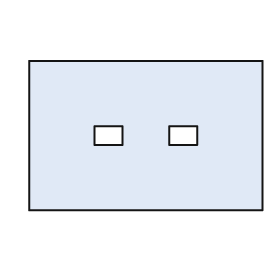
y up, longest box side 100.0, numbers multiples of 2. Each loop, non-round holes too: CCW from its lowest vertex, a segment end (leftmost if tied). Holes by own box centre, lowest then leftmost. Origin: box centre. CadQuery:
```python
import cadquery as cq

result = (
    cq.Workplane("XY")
    .moveTo(-50.0, -32.0)
    .lineTo(50.0, -32.0)
    .lineTo(50.0, 32.0)
    .lineTo(-50.0, 32.0)
    .close()
    .moveTo(-22.0, -4.0)
    .lineTo(-10.0, -4.0)
    .lineTo(-10.0, 4.0)
    .lineTo(-22.0, 4.0)
    .close()
    .moveTo(10.0, -4.0)
    .lineTo(22.0, -4.0)
    .lineTo(22.0, 4.0)
    .lineTo(10.0, 4.0)
    .close()
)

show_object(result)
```